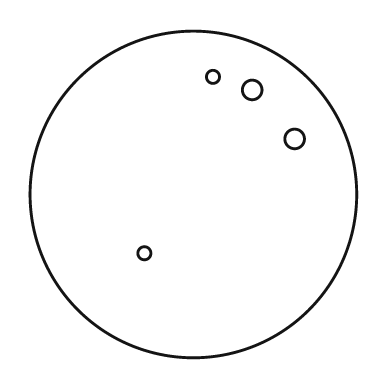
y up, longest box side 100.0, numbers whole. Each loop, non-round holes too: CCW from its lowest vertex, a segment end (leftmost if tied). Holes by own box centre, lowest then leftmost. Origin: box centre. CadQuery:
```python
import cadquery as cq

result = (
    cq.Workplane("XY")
    .moveTo(0.0, 0.0)
    .circle(50.0)
    .moveTo(-15.0, -18.0)
    .circle(2.0)
    .moveTo(31.0, 17.0)
    .circle(3.0)
    .moveTo(18.0, 32.0)
    .circle(3.0)
    .moveTo(6.0, 36.0)
    .circle(2.0)
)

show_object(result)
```